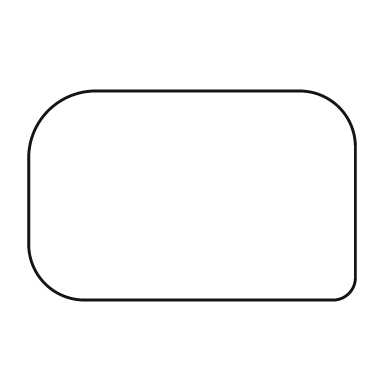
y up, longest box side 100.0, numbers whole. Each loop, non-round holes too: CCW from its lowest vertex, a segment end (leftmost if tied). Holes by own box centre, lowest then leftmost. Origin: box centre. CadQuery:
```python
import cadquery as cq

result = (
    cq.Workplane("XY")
    .moveTo(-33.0, -32.0)
    .lineTo(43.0, -32.0)
    .threePointArc((48.0, -30.0), (50.0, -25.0))
    .lineTo(50.0, 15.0)
    .threePointArc((45.0, 27.0), (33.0, 32.0))
    .lineTo(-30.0, 32.0)
    .threePointArc((-44.0, 26.0), (-50.0, 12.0))
    .lineTo(-50.0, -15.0)
    .threePointArc((-45.0, -27.0), (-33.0, -32.0))
    .close()
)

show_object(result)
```